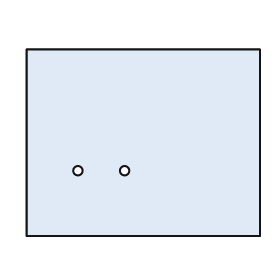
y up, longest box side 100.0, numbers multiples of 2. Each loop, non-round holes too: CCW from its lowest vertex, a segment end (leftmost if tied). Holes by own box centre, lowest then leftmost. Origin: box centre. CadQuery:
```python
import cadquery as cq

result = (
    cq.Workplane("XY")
    .moveTo(-50.0, -40.0)
    .lineTo(50.0, -40.0)
    .lineTo(50.0, 40.0)
    .lineTo(-50.0, 40.0)
    .close()
    .moveTo(-28.0, -12.0)
    .circle(2.0)
    .moveTo(-8.0, -12.0)
    .circle(2.0)
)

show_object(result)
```